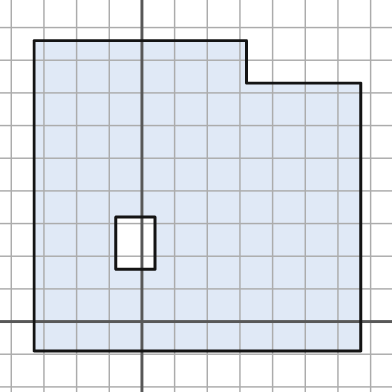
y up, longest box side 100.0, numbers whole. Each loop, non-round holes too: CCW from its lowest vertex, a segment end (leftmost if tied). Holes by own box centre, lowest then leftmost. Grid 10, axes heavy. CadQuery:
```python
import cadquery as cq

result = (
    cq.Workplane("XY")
    .moveTo(-33.0, -9.0)
    .lineTo(67.0, -9.0)
    .lineTo(67.0, 73.0)
    .lineTo(32.0, 73.0)
    .lineTo(32.0, 86.0)
    .lineTo(-33.0, 86.0)
    .close()
    .moveTo(-8.0, 16.0)
    .lineTo(4.0, 16.0)
    .lineTo(4.0, 32.0)
    .lineTo(-8.0, 32.0)
    .close()
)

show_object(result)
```